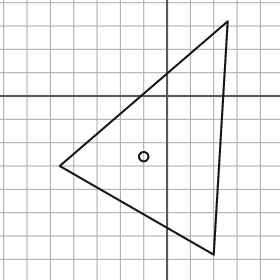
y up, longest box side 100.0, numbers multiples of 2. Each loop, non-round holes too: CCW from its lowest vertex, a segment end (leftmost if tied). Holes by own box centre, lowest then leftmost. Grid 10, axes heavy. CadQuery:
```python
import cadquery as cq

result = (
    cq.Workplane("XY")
    .moveTo(20.0, -68.0)
    .lineTo(26.0, 32.0)
    .lineTo(-46.0, -30.0)
    .close()
    .moveTo(-10.0, -26.0)
    .circle(2.0)
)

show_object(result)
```